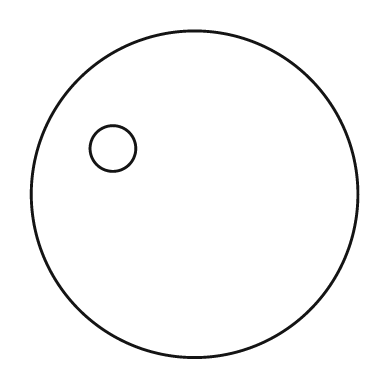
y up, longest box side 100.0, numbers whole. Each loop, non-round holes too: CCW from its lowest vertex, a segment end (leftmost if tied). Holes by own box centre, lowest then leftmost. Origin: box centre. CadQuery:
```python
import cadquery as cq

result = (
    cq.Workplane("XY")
    .moveTo(0.0, 0.0)
    .circle(50.0)
    .moveTo(-25.0, 14.0)
    .circle(7.0)
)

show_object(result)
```